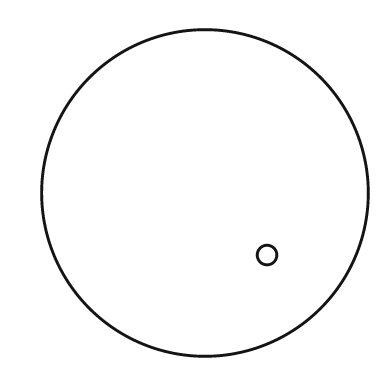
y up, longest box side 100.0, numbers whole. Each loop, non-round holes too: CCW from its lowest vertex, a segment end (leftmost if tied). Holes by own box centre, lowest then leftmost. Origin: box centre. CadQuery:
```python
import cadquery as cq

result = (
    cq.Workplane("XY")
    .moveTo(0.0, 0.0)
    .circle(50.0)
    .moveTo(19.0, -19.0)
    .circle(3.0)
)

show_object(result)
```